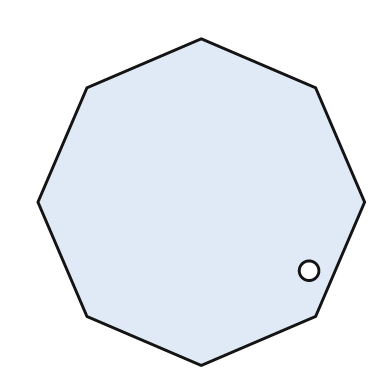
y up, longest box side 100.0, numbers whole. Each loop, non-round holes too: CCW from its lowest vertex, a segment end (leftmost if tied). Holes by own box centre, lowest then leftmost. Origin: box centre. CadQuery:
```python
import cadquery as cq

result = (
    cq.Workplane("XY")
    .moveTo(0.0, -50.0)
    .lineTo(35.0, -35.0)
    .lineTo(50.0, 0.0)
    .lineTo(35.0, 35.0)
    .lineTo(0.0, 50.0)
    .lineTo(-35.0, 35.0)
    .lineTo(-50.0, 0.0)
    .lineTo(-35.0, -35.0)
    .close()
    .moveTo(33.0, -21.0)
    .circle(3.0)
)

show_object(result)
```